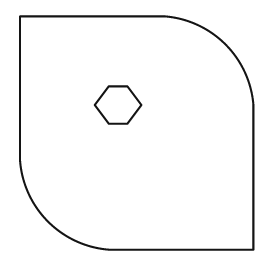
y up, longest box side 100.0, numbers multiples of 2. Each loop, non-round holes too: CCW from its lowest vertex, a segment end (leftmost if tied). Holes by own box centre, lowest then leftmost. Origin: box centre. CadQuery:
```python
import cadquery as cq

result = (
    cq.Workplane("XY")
    .moveTo(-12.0, -50.0)
    .lineTo(50.0, -50.0)
    .lineTo(50.0, 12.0)
    .threePointArc((38.0, 38.0), (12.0, 50.0))
    .lineTo(-50.0, 50.0)
    .lineTo(-50.0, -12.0)
    .threePointArc((-38.0, -38.0), (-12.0, -50.0))
    .close()
    .moveTo(-12.0, 4.0)
    .lineTo(-4.0, 4.0)
    .lineTo(2.0, 12.0)
    .lineTo(-4.0, 20.0)
    .lineTo(-12.0, 20.0)
    .lineTo(-18.0, 12.0)
    .close()
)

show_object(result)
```